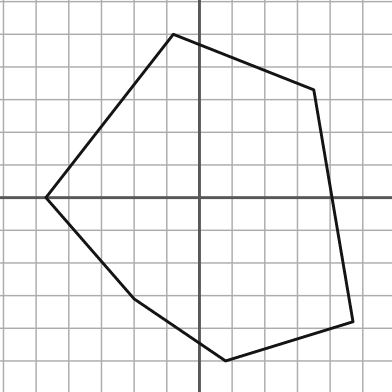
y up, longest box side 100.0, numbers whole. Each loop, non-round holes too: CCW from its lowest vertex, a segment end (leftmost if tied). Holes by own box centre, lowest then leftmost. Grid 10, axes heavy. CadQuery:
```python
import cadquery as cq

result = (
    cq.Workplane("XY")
    .moveTo(8.0, -50.0)
    .lineTo(47.0, -38.0)
    .lineTo(35.0, 33.0)
    .lineTo(-8.0, 50.0)
    .lineTo(-47.0, 0.0)
    .lineTo(-20.0, -31.0)
    .close()
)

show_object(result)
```